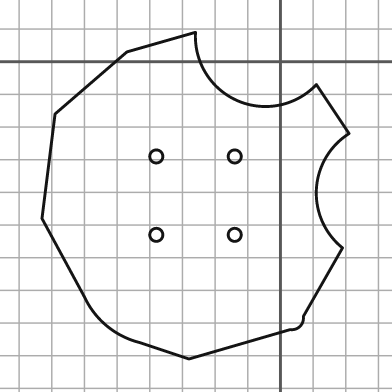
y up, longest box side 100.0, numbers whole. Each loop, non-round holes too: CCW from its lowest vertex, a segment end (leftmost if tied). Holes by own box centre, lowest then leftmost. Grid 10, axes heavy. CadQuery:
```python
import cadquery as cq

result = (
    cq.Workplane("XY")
    .moveTo(-28.0, -91.0)
    .lineTo(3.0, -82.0)
    .threePointArc((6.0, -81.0), (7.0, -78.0))
    .lineTo(19.0, -57.0)
    .threePointArc((11.0, -39.0), (21.0, -22.0))
    .lineTo(11.0, -7.0)
    .threePointArc((-13.0, -12.0), (-26.0, 9.0))
    .lineTo(-47.0, 3.0)
    .lineTo(-69.0, -16.0)
    .lineTo(-73.0, -48.0)
    .lineTo(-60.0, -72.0)
    .threePointArc((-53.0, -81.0), (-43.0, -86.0))
    .close()
    .moveTo(-38.0, -53.0)
    .circle(2.0)
    .moveTo(-14.0, -53.0)
    .circle(2.0)
    .moveTo(-38.0, -29.0)
    .circle(2.0)
    .moveTo(-14.0, -29.0)
    .circle(2.0)
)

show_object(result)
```